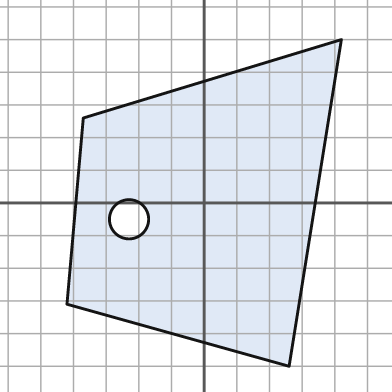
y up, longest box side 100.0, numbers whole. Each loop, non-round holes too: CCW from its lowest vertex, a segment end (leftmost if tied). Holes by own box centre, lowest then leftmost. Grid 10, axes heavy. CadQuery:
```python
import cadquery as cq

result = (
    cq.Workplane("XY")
    .moveTo(26.0, -50.0)
    .lineTo(42.0, 50.0)
    .lineTo(-37.0, 26.0)
    .lineTo(-42.0, -31.0)
    .close()
    .moveTo(-23.0, -5.0)
    .circle(6.0)
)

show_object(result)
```